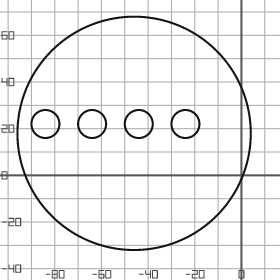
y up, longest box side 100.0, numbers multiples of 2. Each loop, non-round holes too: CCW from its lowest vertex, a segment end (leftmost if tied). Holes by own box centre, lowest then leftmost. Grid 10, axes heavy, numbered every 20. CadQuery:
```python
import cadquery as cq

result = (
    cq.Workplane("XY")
    .moveTo(-46.0, 18.0)
    .circle(50.0)
    .moveTo(-84.0, 22.0)
    .circle(6.0)
    .moveTo(-64.0, 22.0)
    .circle(6.0)
    .moveTo(-44.0, 22.0)
    .circle(6.0)
    .moveTo(-24.0, 22.0)
    .circle(6.0)
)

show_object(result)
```